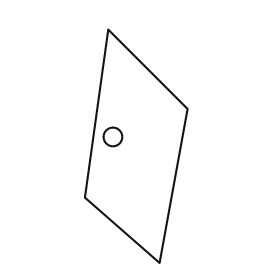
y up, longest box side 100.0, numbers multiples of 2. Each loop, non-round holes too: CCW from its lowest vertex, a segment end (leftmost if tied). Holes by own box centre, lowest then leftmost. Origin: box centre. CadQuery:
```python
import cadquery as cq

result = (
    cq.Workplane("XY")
    .moveTo(10.0, -50.0)
    .lineTo(22.0, 16.0)
    .lineTo(-12.0, 50.0)
    .lineTo(-22.0, -22.0)
    .close()
    .moveTo(-10.0, 4.0)
    .circle(4.0)
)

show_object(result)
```